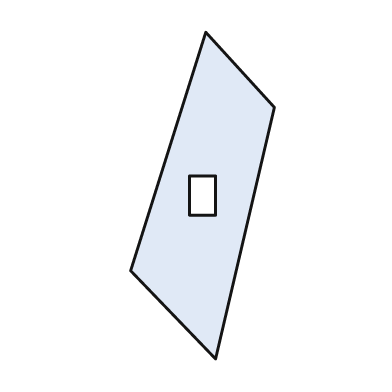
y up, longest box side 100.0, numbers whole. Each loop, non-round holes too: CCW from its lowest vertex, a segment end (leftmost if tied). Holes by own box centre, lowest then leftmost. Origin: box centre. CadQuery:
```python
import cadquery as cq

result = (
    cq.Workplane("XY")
    .moveTo(4.0, -50.0)
    .lineTo(22.0, 27.0)
    .lineTo(1.0, 50.0)
    .lineTo(-22.0, -23.0)
    .close()
    .moveTo(-4.0, -6.0)
    .lineTo(4.0, -6.0)
    .lineTo(4.0, 6.0)
    .lineTo(-4.0, 6.0)
    .close()
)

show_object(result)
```